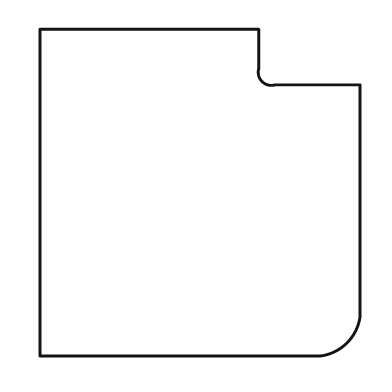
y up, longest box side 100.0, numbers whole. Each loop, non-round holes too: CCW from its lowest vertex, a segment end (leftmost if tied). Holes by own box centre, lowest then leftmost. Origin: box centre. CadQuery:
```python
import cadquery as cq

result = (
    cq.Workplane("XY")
    .moveTo(-49.0, -50.0)
    .lineTo(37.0, -50.0)
    .threePointArc((45.0, -46.0), (49.0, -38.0))
    .lineTo(49.0, 33.0)
    .lineTo(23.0, 33.0)
    .threePointArc((19.0, 34.0), (18.0, 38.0))
    .lineTo(18.0, 50.0)
    .lineTo(-49.0, 50.0)
    .close()
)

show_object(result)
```